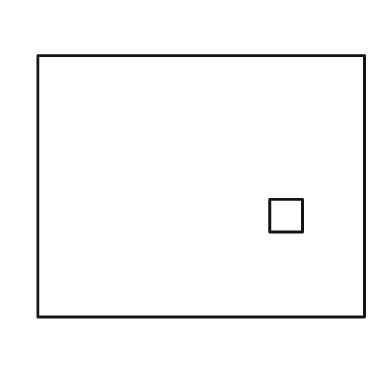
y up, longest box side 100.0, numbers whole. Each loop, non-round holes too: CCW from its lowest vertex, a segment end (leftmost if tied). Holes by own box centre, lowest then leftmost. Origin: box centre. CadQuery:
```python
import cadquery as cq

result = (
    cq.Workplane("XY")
    .moveTo(-50.0, -40.0)
    .lineTo(50.0, -40.0)
    .lineTo(50.0, 40.0)
    .lineTo(-50.0, 40.0)
    .close()
    .moveTo(21.0, -14.0)
    .lineTo(31.0, -14.0)
    .lineTo(31.0, -4.0)
    .lineTo(21.0, -4.0)
    .close()
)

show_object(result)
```